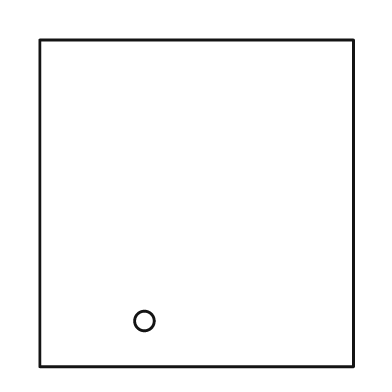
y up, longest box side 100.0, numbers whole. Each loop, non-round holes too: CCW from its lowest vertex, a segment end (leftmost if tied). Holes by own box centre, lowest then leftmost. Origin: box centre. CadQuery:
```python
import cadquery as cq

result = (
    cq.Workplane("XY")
    .moveTo(-48.0, -50.0)
    .lineTo(48.0, -50.0)
    .lineTo(48.0, 50.0)
    .lineTo(-48.0, 50.0)
    .close()
    .moveTo(-16.0, -36.0)
    .circle(3.0)
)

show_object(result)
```